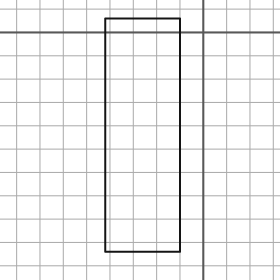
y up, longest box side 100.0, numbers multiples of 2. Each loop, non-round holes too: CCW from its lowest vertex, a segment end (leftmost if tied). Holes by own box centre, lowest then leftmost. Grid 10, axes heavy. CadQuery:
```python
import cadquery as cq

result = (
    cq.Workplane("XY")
    .moveTo(-42.0, -94.0)
    .lineTo(-10.0, -94.0)
    .lineTo(-10.0, 6.0)
    .lineTo(-42.0, 6.0)
    .close()
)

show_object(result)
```